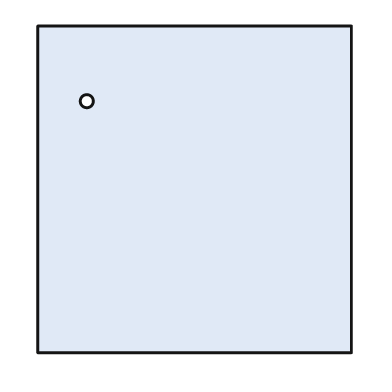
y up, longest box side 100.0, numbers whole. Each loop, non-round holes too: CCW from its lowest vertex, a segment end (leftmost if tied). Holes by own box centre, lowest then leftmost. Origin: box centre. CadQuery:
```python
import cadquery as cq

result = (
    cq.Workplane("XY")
    .moveTo(-48.0, -50.0)
    .lineTo(48.0, -50.0)
    .lineTo(48.0, 50.0)
    .lineTo(-48.0, 50.0)
    .close()
    .moveTo(-33.0, 27.0)
    .circle(2.0)
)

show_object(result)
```